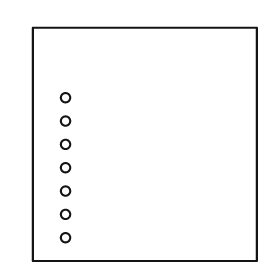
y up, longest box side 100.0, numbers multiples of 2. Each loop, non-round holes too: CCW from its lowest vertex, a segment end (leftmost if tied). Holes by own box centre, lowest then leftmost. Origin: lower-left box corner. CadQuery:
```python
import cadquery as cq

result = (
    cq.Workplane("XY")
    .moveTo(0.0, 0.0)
    .lineTo(96.0, 0.0)
    .lineTo(96.0, 100.0)
    .lineTo(0.0, 100.0)
    .close()
    .moveTo(14.0, 10.0)
    .circle(2.0)
    .moveTo(14.0, 20.0)
    .circle(2.0)
    .moveTo(14.0, 30.0)
    .circle(2.0)
    .moveTo(14.0, 40.0)
    .circle(2.0)
    .moveTo(14.0, 50.0)
    .circle(2.0)
    .moveTo(14.0, 60.0)
    .circle(2.0)
    .moveTo(14.0, 70.0)
    .circle(2.0)
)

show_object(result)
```